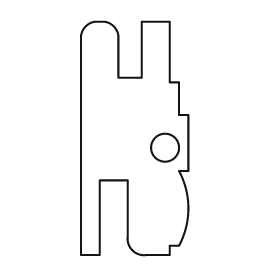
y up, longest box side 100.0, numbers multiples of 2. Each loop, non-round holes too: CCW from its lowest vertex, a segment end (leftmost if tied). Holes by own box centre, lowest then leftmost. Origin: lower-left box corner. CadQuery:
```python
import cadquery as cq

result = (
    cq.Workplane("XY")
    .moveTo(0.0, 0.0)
    .lineTo(8.0, 0.0)
    .lineTo(8.0, 32.0)
    .lineTo(20.0, 32.0)
    .lineTo(20.0, 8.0)
    .threePointArc((22.0, 2.0), (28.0, 0.0))
    .lineTo(38.0, 0.0)
    .lineTo(38.0, 4.0)
    .lineTo(42.0, 4.0)
    .threePointArc((46.0, 20.0), (42.0, 36.0))
    .lineTo(46.0, 36.0)
    .lineTo(46.0, 60.0)
    .lineTo(42.0, 60.0)
    .lineTo(42.0, 74.0)
    .lineTo(38.0, 74.0)
    .lineTo(38.0, 100.0)
    .lineTo(26.0, 100.0)
    .lineTo(26.0, 76.0)
    .lineTo(16.0, 76.0)
    .lineTo(16.0, 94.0)
    .threePointArc((14.0, 98.0), (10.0, 100.0))
    .lineTo(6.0, 100.0)
    .threePointArc((2.0, 98.0), (0.0, 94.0))
    .close()
    .moveTo(36.0, 46.0)
    .circle(6.0)
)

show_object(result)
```